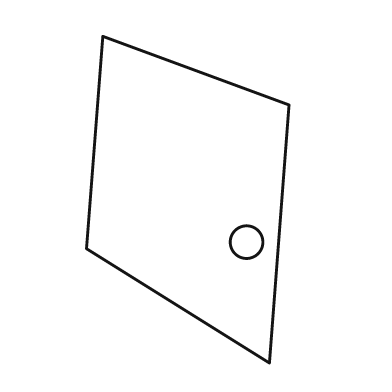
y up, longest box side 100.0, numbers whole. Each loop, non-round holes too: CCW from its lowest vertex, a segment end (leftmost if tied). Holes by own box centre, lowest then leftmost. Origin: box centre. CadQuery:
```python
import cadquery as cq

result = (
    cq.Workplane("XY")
    .moveTo(25.0, -50.0)
    .lineTo(31.0, 29.0)
    .lineTo(-26.0, 50.0)
    .lineTo(-31.0, -15.0)
    .close()
    .moveTo(18.0, -13.0)
    .circle(5.0)
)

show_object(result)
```